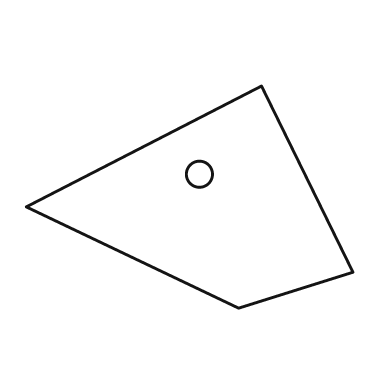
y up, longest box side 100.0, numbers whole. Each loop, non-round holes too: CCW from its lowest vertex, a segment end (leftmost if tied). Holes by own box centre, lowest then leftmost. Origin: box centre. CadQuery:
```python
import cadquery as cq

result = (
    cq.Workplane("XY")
    .moveTo(15.0, -34.0)
    .lineTo(50.0, -23.0)
    .lineTo(22.0, 34.0)
    .lineTo(-50.0, -3.0)
    .close()
    .moveTo(3.0, 7.0)
    .circle(4.0)
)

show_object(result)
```